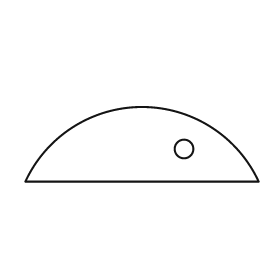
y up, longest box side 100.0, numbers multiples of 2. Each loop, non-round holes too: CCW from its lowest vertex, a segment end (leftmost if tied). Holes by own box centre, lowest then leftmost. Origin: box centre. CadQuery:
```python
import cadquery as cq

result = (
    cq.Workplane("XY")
    .moveTo(-50.0, -16.0)
    .lineTo(50.0, -16.0)
    .threePointArc((0.0, 16.0), (-50.0, -16.0))
    .close()
    .moveTo(18.0, -2.0)
    .circle(4.0)
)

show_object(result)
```